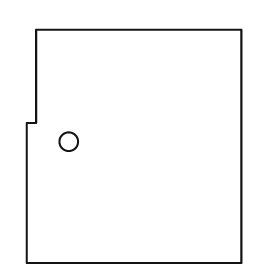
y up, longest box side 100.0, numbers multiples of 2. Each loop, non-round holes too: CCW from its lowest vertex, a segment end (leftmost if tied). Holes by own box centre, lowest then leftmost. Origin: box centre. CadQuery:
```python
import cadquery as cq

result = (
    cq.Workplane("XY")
    .moveTo(-46.0, -50.0)
    .lineTo(46.0, -50.0)
    .lineTo(46.0, 50.0)
    .lineTo(-42.0, 50.0)
    .lineTo(-42.0, 10.0)
    .lineTo(-46.0, 10.0)
    .close()
    .moveTo(-28.0, 2.0)
    .circle(4.0)
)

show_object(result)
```